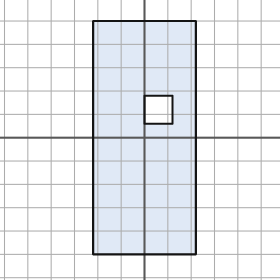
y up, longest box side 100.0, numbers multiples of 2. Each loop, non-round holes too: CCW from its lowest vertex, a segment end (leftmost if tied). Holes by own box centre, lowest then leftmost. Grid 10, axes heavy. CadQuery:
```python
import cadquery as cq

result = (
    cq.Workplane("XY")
    .moveTo(-22.0, -50.0)
    .lineTo(22.0, -50.0)
    .lineTo(22.0, 50.0)
    .lineTo(-22.0, 50.0)
    .close()
    .moveTo(0.0, 6.0)
    .lineTo(12.0, 6.0)
    .lineTo(12.0, 18.0)
    .lineTo(0.0, 18.0)
    .close()
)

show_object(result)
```